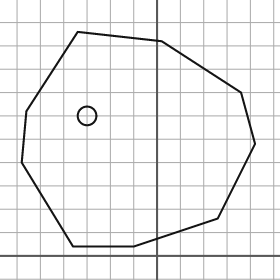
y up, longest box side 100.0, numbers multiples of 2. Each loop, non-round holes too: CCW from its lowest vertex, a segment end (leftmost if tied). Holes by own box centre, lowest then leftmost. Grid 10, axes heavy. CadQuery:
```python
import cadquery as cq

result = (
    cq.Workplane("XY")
    .moveTo(-36.0, 4.0)
    .lineTo(-10.0, 4.0)
    .lineTo(26.0, 16.0)
    .lineTo(42.0, 48.0)
    .lineTo(36.0, 70.0)
    .lineTo(2.0, 92.0)
    .lineTo(-34.0, 96.0)
    .lineTo(-56.0, 62.0)
    .lineTo(-58.0, 40.0)
    .close()
    .moveTo(-30.0, 60.0)
    .circle(4.0)
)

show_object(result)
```